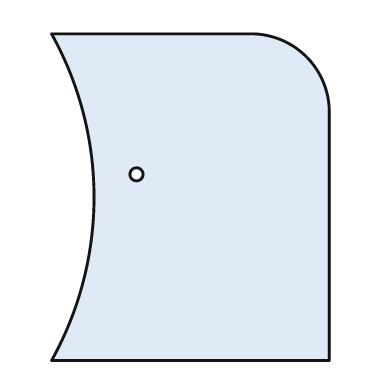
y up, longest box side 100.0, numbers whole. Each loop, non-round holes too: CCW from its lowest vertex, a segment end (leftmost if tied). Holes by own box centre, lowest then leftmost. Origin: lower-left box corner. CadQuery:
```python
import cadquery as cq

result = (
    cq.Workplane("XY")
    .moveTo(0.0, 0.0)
    .lineTo(85.0, 0.0)
    .lineTo(85.0, 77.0)
    .threePointArc((78.0, 93.0), (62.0, 100.0))
    .lineTo(0.0, 100.0)
    .threePointArc((13.0, 50.0), (0.0, 0.0))
    .close()
    .moveTo(26.0, 57.0)
    .circle(2.0)
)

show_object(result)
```